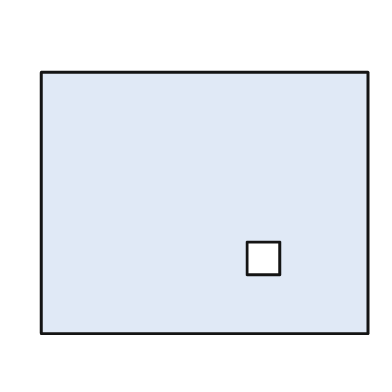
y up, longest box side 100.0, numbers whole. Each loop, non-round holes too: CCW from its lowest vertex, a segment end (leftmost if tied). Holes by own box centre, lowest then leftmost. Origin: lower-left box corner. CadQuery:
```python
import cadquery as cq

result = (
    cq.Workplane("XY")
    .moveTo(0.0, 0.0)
    .lineTo(100.0, 0.0)
    .lineTo(100.0, 80.0)
    .lineTo(0.0, 80.0)
    .close()
    .moveTo(63.0, 18.0)
    .lineTo(73.0, 18.0)
    .lineTo(73.0, 28.0)
    .lineTo(63.0, 28.0)
    .close()
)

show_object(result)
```